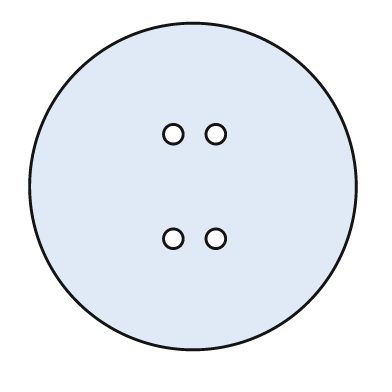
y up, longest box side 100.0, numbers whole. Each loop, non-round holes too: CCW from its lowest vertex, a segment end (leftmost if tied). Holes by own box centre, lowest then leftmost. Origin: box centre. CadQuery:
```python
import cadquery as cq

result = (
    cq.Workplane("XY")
    .moveTo(0.0, 0.0)
    .circle(50.0)
    .moveTo(-6.0, -16.0)
    .circle(3.0)
    .moveTo(7.0, -16.0)
    .circle(3.0)
    .moveTo(-6.0, 16.0)
    .circle(3.0)
    .moveTo(7.0, 16.0)
    .circle(3.0)
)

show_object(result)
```